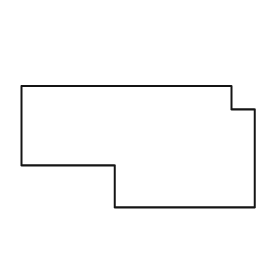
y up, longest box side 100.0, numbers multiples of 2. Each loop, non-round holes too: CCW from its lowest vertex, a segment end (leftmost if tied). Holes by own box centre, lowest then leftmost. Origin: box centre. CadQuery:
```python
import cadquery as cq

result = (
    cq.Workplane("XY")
    .moveTo(-10.0, -26.0)
    .lineTo(50.0, -26.0)
    .lineTo(50.0, 16.0)
    .lineTo(40.0, 16.0)
    .lineTo(40.0, 26.0)
    .lineTo(-50.0, 26.0)
    .lineTo(-50.0, -8.0)
    .lineTo(-10.0, -8.0)
    .close()
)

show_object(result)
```